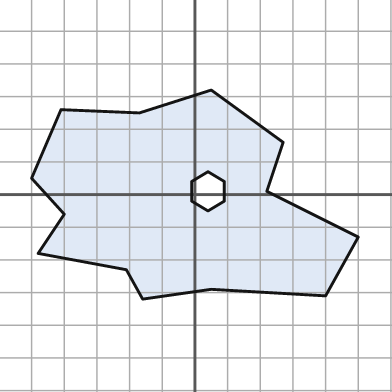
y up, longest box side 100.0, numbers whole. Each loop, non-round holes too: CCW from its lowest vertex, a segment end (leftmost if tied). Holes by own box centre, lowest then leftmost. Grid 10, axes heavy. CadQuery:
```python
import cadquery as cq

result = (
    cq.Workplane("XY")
    .moveTo(-16.0, -32.0)
    .lineTo(5.0, -29.0)
    .lineTo(40.0, -31.0)
    .lineTo(50.0, -13.0)
    .lineTo(22.0, 1.0)
    .lineTo(27.0, 16.0)
    .lineTo(5.0, 32.0)
    .lineTo(-17.0, 25.0)
    .lineTo(-41.0, 26.0)
    .lineTo(-50.0, 5.0)
    .lineTo(-40.0, -6.0)
    .lineTo(-48.0, -18.0)
    .lineTo(-21.0, -23.0)
    .close()
    .moveTo(4.0, -5.0)
    .lineTo(9.0, -2.0)
    .lineTo(9.0, 4.0)
    .lineTo(4.0, 7.0)
    .lineTo(-1.0, 4.0)
    .lineTo(-1.0, -2.0)
    .close()
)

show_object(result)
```